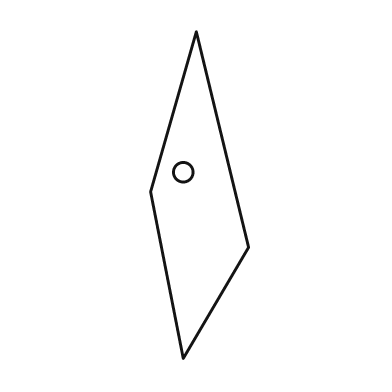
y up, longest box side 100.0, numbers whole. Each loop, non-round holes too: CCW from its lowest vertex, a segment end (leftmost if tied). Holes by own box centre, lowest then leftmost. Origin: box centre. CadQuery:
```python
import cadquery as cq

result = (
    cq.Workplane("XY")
    .moveTo(-5.0, -50.0)
    .lineTo(15.0, -16.0)
    .lineTo(-1.0, 50.0)
    .lineTo(-15.0, 1.0)
    .close()
    .moveTo(-5.0, 7.0)
    .circle(3.0)
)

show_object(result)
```